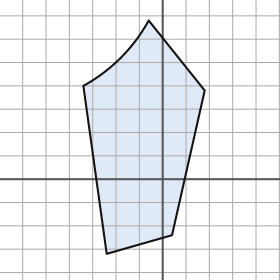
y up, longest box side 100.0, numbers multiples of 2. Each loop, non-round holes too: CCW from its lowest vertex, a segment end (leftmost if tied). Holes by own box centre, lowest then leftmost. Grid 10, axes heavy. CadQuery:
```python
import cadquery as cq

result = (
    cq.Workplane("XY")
    .moveTo(-24.0, -32.0)
    .lineTo(4.0, -24.0)
    .lineTo(18.0, 38.0)
    .lineTo(-6.0, 68.0)
    .threePointArc((-18.0, 52.0), (-34.0, 40.0))
    .close()
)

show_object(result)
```